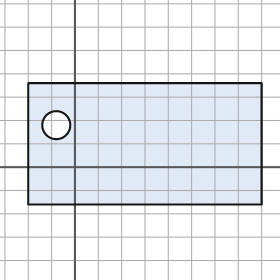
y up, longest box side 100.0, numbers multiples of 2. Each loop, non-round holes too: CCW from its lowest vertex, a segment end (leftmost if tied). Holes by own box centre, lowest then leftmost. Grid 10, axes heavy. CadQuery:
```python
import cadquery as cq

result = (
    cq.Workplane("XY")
    .moveTo(-20.0, -16.0)
    .lineTo(80.0, -16.0)
    .lineTo(80.0, 36.0)
    .lineTo(-20.0, 36.0)
    .close()
    .moveTo(-8.0, 18.0)
    .circle(6.0)
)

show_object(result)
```